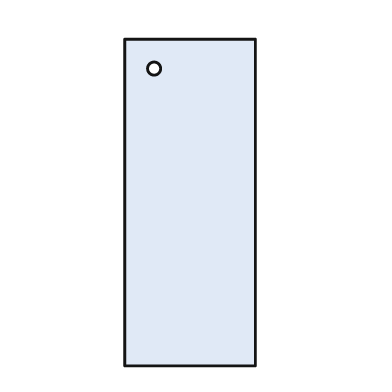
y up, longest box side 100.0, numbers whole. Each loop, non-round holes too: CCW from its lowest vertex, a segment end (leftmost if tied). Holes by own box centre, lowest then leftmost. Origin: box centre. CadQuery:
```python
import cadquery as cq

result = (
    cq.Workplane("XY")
    .moveTo(-20.0, -50.0)
    .lineTo(20.0, -50.0)
    .lineTo(20.0, 50.0)
    .lineTo(-20.0, 50.0)
    .close()
    .moveTo(-11.0, 41.0)
    .circle(2.0)
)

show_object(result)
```